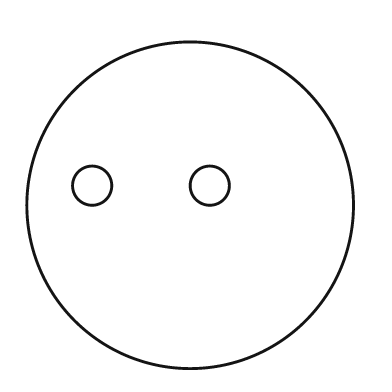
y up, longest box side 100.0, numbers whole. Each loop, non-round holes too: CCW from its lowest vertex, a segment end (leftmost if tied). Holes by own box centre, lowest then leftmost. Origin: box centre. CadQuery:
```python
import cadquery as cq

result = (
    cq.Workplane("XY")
    .moveTo(0.0, 0.0)
    .circle(50.0)
    .moveTo(-30.0, 6.0)
    .circle(6.0)
    .moveTo(6.0, 6.0)
    .circle(6.0)
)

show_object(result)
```